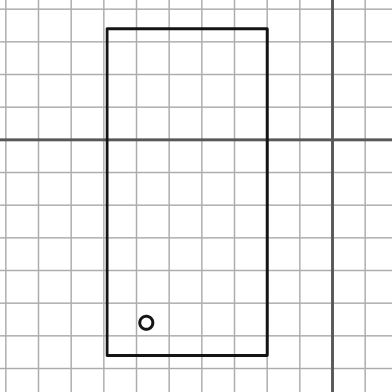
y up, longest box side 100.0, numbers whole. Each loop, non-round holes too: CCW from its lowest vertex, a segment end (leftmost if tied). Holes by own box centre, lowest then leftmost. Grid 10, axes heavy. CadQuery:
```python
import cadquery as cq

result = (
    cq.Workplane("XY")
    .moveTo(-69.0, -66.0)
    .lineTo(-20.0, -66.0)
    .lineTo(-20.0, 34.0)
    .lineTo(-69.0, 34.0)
    .close()
    .moveTo(-57.0, -56.0)
    .circle(2.0)
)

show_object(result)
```